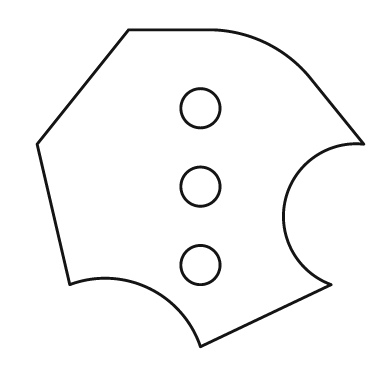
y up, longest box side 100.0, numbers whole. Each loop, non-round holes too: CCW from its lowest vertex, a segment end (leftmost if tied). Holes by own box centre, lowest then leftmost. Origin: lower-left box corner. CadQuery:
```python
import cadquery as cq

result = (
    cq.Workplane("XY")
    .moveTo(50.0, 0.0)
    .lineTo(90.0, 19.0)
    .threePointArc((76.0, 45.0), (100.0, 62.0))
    .lineTo(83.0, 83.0)
    .threePointArc((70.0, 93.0), (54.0, 97.0))
    .lineTo(28.0, 97.0)
    .lineTo(0.0, 62.0)
    .lineTo(10.0, 19.0)
    .threePointArc((34.0, 18.0), (50.0, 0.0))
    .close()
    .moveTo(50.0, 25.0)
    .circle(6.0)
    .moveTo(50.0, 49.0)
    .circle(6.0)
    .moveTo(50.0, 73.0)
    .circle(6.0)
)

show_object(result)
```